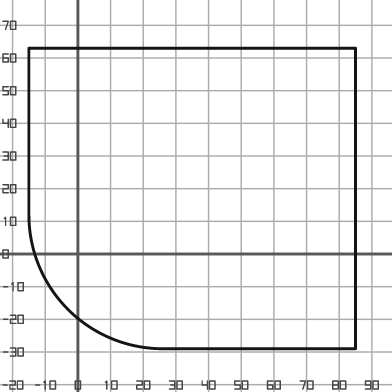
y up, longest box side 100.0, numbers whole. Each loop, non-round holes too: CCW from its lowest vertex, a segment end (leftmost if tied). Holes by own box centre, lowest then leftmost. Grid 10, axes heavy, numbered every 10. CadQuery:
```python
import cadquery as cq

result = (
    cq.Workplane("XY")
    .moveTo(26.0, -29.0)
    .lineTo(85.0, -29.0)
    .lineTo(85.0, 63.0)
    .lineTo(-15.0, 63.0)
    .lineTo(-15.0, 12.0)
    .threePointArc((-3.0, -17.0), (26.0, -29.0))
    .close()
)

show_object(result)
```